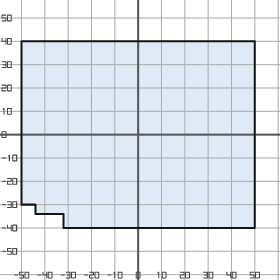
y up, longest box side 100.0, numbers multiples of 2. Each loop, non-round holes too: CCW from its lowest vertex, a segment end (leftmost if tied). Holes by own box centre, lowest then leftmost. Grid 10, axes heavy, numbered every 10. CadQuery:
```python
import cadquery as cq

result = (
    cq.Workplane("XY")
    .moveTo(-32.0, -40.0)
    .lineTo(50.0, -40.0)
    .lineTo(50.0, 40.0)
    .lineTo(-50.0, 40.0)
    .lineTo(-50.0, -30.0)
    .lineTo(-44.0, -30.0)
    .lineTo(-44.0, -34.0)
    .lineTo(-32.0, -34.0)
    .close()
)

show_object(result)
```